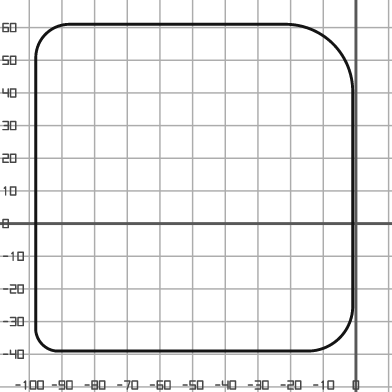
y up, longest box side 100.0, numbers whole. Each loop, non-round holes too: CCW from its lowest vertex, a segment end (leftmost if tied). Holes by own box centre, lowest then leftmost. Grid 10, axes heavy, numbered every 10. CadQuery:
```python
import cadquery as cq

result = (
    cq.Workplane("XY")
    .moveTo(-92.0, -39.0)
    .lineTo(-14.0, -39.0)
    .threePointArc((-5.0, -35.0), (-1.0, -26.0))
    .lineTo(-1.0, 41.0)
    .threePointArc((-7.0, 55.0), (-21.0, 61.0))
    .lineTo(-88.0, 61.0)
    .threePointArc((-95.0, 58.0), (-98.0, 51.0))
    .lineTo(-98.0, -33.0)
    .threePointArc((-96.0, -37.0), (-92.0, -39.0))
    .close()
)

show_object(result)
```